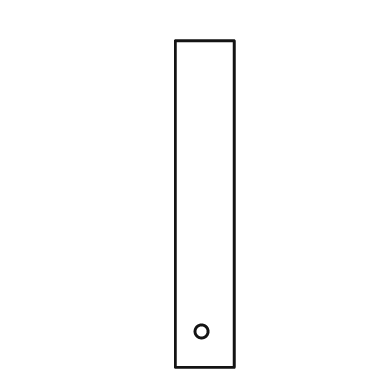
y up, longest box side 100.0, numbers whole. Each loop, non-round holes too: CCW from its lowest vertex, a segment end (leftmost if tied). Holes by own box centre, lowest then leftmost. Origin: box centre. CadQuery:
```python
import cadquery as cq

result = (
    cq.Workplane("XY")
    .moveTo(-9.0, -50.0)
    .lineTo(9.0, -50.0)
    .lineTo(9.0, 50.0)
    .lineTo(-9.0, 50.0)
    .close()
    .moveTo(-1.0, -39.0)
    .circle(2.0)
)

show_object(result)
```